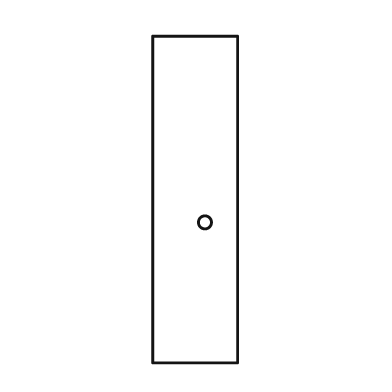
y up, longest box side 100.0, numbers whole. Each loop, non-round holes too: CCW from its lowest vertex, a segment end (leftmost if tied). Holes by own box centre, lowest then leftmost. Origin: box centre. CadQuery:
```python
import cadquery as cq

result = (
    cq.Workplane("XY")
    .moveTo(-13.0, -50.0)
    .lineTo(13.0, -50.0)
    .lineTo(13.0, 50.0)
    .lineTo(-13.0, 50.0)
    .close()
    .moveTo(3.0, -7.0)
    .circle(2.0)
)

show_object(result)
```